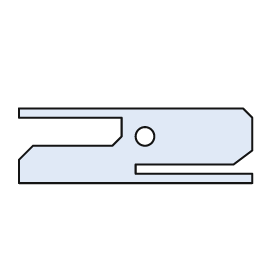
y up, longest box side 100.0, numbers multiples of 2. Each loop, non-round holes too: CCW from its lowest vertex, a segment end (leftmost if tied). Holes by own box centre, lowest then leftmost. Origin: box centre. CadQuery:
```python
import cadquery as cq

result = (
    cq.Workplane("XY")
    .moveTo(-50.0, -16.0)
    .lineTo(50.0, -16.0)
    .lineTo(50.0, -12.0)
    .lineTo(0.0, -12.0)
    .lineTo(0.0, -8.0)
    .lineTo(42.0, -8.0)
    .lineTo(50.0, -2.0)
    .lineTo(50.0, 12.0)
    .lineTo(46.0, 16.0)
    .lineTo(-50.0, 16.0)
    .lineTo(-50.0, 12.0)
    .lineTo(-6.0, 12.0)
    .lineTo(-6.0, 4.0)
    .lineTo(-10.0, 0.0)
    .lineTo(-44.0, 0.0)
    .lineTo(-50.0, -6.0)
    .close()
    .moveTo(4.0, 4.0)
    .circle(4.0)
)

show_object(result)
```